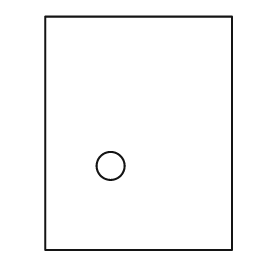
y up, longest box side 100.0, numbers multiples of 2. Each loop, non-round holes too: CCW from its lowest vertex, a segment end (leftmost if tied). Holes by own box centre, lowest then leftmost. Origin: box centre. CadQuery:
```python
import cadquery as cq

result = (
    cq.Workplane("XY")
    .moveTo(-40.0, -50.0)
    .lineTo(40.0, -50.0)
    .lineTo(40.0, 50.0)
    .lineTo(-40.0, 50.0)
    .close()
    .moveTo(-12.0, -14.0)
    .circle(6.0)
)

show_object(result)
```